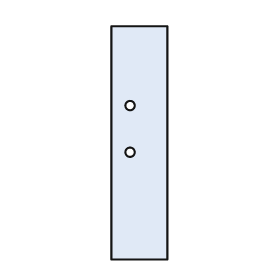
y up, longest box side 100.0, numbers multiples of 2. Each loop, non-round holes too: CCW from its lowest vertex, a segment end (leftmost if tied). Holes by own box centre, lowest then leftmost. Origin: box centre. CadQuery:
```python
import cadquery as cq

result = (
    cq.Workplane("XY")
    .moveTo(-12.0, -50.0)
    .lineTo(12.0, -50.0)
    .lineTo(12.0, 50.0)
    .lineTo(-12.0, 50.0)
    .close()
    .moveTo(-4.0, -4.0)
    .circle(2.0)
    .moveTo(-4.0, 16.0)
    .circle(2.0)
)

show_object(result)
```